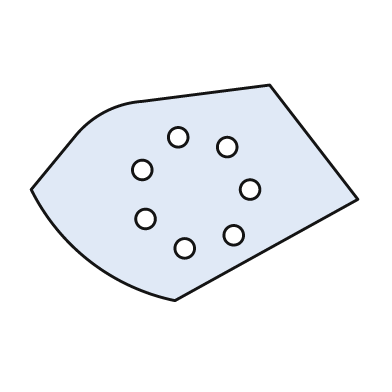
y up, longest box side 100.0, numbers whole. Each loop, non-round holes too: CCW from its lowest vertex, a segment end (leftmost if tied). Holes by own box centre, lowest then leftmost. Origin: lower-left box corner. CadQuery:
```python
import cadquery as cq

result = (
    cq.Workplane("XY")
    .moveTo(44.0, 0.0)
    .lineTo(100.0, 31.0)
    .lineTo(73.0, 66.0)
    .lineTo(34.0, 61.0)
    .threePointArc((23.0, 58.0), (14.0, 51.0))
    .lineTo(0.0, 34.0)
    .threePointArc((18.0, 12.0), (44.0, 0.0))
    .close()
    .moveTo(47.0, 16.0)
    .circle(3.0)
    .moveTo(62.0, 20.0)
    .circle(3.0)
    .moveTo(35.0, 25.0)
    .circle(3.0)
    .moveTo(67.0, 34.0)
    .circle(3.0)
    .moveTo(34.0, 40.0)
    .circle(3.0)
    .moveTo(60.0, 47.0)
    .circle(3.0)
    .moveTo(45.0, 50.0)
    .circle(3.0)
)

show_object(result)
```